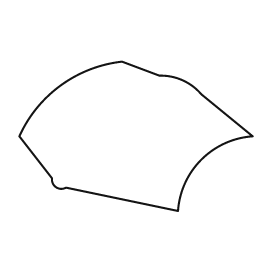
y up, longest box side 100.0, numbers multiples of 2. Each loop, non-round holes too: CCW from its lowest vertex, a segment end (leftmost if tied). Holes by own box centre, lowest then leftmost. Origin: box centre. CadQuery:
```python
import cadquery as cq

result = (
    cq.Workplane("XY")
    .moveTo(18.0, -32.0)
    .threePointArc((28.0, -10.0), (50.0, 0.0))
    .lineTo(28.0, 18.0)
    .threePointArc((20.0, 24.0), (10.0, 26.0))
    .lineTo(-6.0, 32.0)
    .threePointArc((-32.0, 22.0), (-50.0, 0.0))
    .lineTo(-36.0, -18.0)
    .threePointArc((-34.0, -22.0), (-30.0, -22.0))
    .close()
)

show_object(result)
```